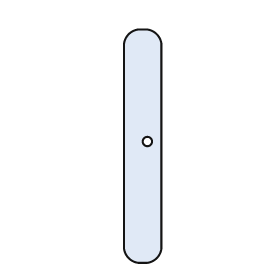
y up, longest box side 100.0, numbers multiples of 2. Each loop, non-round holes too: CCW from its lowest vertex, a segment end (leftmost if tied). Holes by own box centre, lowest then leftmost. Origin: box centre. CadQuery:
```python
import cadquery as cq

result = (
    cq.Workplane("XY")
    .moveTo(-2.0, -50.0)
    .lineTo(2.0, -50.0)
    .threePointArc((6.0, -48.0), (8.0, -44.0))
    .lineTo(8.0, 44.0)
    .threePointArc((6.0, 48.0), (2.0, 50.0))
    .lineTo(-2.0, 50.0)
    .threePointArc((-6.0, 48.0), (-8.0, 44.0))
    .lineTo(-8.0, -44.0)
    .threePointArc((-6.0, -48.0), (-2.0, -50.0))
    .close()
    .moveTo(2.0, 2.0)
    .circle(2.0)
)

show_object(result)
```